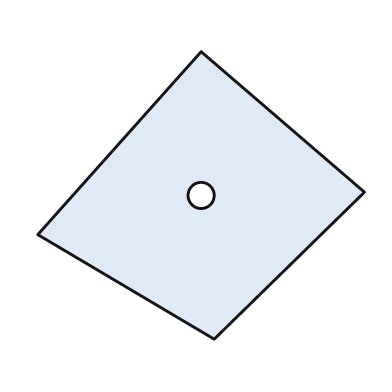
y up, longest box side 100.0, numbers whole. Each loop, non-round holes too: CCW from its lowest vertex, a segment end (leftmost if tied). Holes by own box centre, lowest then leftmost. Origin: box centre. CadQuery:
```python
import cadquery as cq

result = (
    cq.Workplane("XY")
    .moveTo(4.0, -44.0)
    .lineTo(50.0, 1.0)
    .lineTo(0.0, 44.0)
    .lineTo(-50.0, -12.0)
    .close()
    .moveTo(0.0, 0.0)
    .circle(4.0)
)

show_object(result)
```